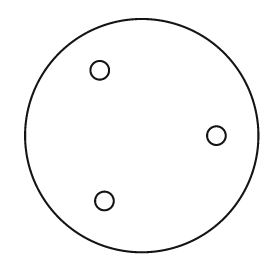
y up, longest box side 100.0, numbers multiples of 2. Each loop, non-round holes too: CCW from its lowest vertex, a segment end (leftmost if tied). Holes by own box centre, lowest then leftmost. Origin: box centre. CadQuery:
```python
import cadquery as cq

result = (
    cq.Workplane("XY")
    .moveTo(0.0, 0.0)
    .circle(50.0)
    .moveTo(-16.0, -28.0)
    .circle(4.0)
    .moveTo(32.0, 0.0)
    .circle(4.0)
    .moveTo(-18.0, 28.0)
    .circle(4.0)
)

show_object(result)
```